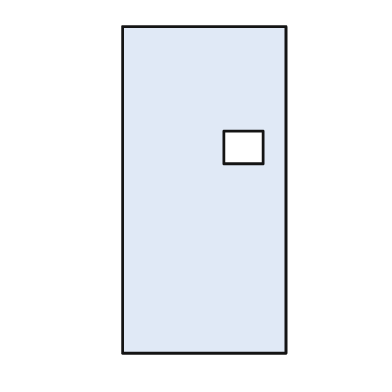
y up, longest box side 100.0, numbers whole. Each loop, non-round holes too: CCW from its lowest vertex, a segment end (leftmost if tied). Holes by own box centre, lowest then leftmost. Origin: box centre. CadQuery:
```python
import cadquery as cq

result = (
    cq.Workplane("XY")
    .moveTo(-25.0, -50.0)
    .lineTo(25.0, -50.0)
    .lineTo(25.0, 50.0)
    .lineTo(-25.0, 50.0)
    .close()
    .moveTo(6.0, 8.0)
    .lineTo(18.0, 8.0)
    .lineTo(18.0, 18.0)
    .lineTo(6.0, 18.0)
    .close()
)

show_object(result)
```